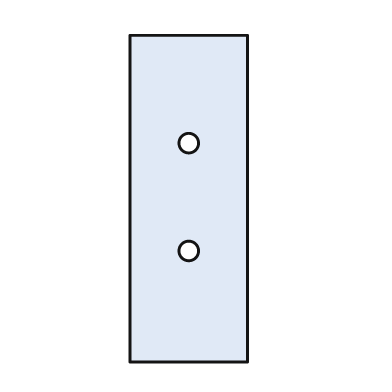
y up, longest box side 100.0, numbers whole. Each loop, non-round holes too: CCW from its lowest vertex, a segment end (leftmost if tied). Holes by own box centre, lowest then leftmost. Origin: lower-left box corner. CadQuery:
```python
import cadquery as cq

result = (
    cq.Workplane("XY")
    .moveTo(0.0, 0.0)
    .lineTo(36.0, 0.0)
    .lineTo(36.0, 100.0)
    .lineTo(0.0, 100.0)
    .close()
    .moveTo(18.0, 34.0)
    .circle(3.0)
    .moveTo(18.0, 67.0)
    .circle(3.0)
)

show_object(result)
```